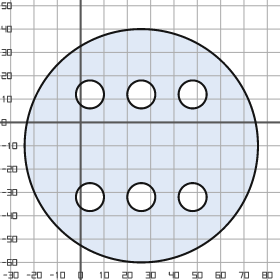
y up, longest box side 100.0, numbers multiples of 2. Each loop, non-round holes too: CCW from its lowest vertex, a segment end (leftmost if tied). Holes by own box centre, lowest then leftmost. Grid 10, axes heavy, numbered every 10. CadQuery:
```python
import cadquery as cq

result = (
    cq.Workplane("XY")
    .moveTo(26.0, -10.0)
    .circle(50.0)
    .moveTo(4.0, -32.0)
    .circle(6.0)
    .moveTo(26.0, -32.0)
    .circle(6.0)
    .moveTo(48.0, -32.0)
    .circle(6.0)
    .moveTo(4.0, 12.0)
    .circle(6.0)
    .moveTo(26.0, 12.0)
    .circle(6.0)
    .moveTo(48.0, 12.0)
    .circle(6.0)
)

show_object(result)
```